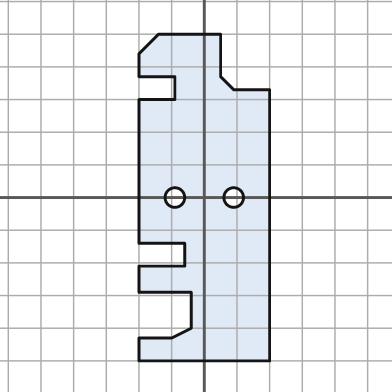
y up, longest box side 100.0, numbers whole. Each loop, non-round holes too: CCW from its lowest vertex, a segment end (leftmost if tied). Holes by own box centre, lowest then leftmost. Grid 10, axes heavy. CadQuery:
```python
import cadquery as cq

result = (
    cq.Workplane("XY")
    .moveTo(-20.0, -50.0)
    .lineTo(20.0, -50.0)
    .lineTo(20.0, 33.0)
    .lineTo(9.0, 33.0)
    .lineTo(5.0, 37.0)
    .lineTo(5.0, 50.0)
    .lineTo(-14.0, 50.0)
    .lineTo(-20.0, 44.0)
    .lineTo(-20.0, 37.0)
    .lineTo(-9.0, 37.0)
    .lineTo(-9.0, 30.0)
    .lineTo(-20.0, 30.0)
    .lineTo(-20.0, -14.0)
    .lineTo(-6.0, -14.0)
    .lineTo(-6.0, -21.0)
    .lineTo(-20.0, -21.0)
    .lineTo(-20.0, -29.0)
    .lineTo(-4.0, -29.0)
    .lineTo(-4.0, -40.0)
    .lineTo(-10.0, -43.0)
    .lineTo(-20.0, -43.0)
    .close()
    .moveTo(-9.0, 0.0)
    .circle(3.0)
    .moveTo(9.0, 0.0)
    .circle(3.0)
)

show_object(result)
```